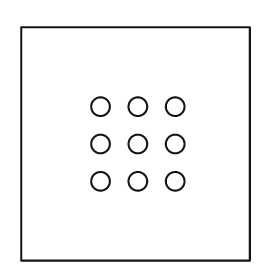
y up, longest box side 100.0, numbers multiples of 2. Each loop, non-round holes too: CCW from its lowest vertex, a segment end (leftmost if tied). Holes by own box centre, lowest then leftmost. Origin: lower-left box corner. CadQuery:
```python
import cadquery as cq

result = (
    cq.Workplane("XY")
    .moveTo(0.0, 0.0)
    .lineTo(98.0, 0.0)
    .lineTo(98.0, 100.0)
    .lineTo(0.0, 100.0)
    .close()
    .moveTo(34.0, 34.0)
    .circle(4.0)
    .moveTo(50.0, 34.0)
    .circle(4.0)
    .moveTo(66.0, 34.0)
    .circle(4.0)
    .moveTo(34.0, 50.0)
    .circle(4.0)
    .moveTo(50.0, 50.0)
    .circle(4.0)
    .moveTo(66.0, 50.0)
    .circle(4.0)
    .moveTo(34.0, 66.0)
    .circle(4.0)
    .moveTo(50.0, 66.0)
    .circle(4.0)
    .moveTo(66.0, 66.0)
    .circle(4.0)
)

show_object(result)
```